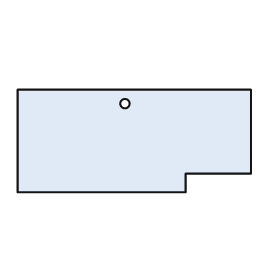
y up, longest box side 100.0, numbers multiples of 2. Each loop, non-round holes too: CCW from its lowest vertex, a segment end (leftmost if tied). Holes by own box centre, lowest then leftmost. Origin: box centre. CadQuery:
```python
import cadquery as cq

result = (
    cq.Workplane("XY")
    .moveTo(-50.0, -22.0)
    .lineTo(22.0, -22.0)
    .lineTo(22.0, -14.0)
    .lineTo(50.0, -14.0)
    .lineTo(50.0, 22.0)
    .lineTo(-50.0, 22.0)
    .close()
    .moveTo(-4.0, 16.0)
    .circle(2.0)
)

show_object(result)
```